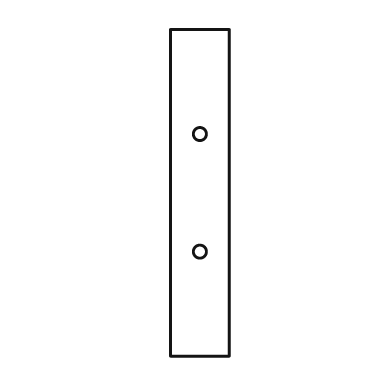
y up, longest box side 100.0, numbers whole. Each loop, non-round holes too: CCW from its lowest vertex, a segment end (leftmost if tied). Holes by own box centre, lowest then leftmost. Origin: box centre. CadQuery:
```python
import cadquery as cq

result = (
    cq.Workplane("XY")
    .moveTo(-9.0, -50.0)
    .lineTo(9.0, -50.0)
    .lineTo(9.0, 50.0)
    .lineTo(-9.0, 50.0)
    .close()
    .moveTo(0.0, -18.0)
    .circle(2.0)
    .moveTo(0.0, 18.0)
    .circle(2.0)
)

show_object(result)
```